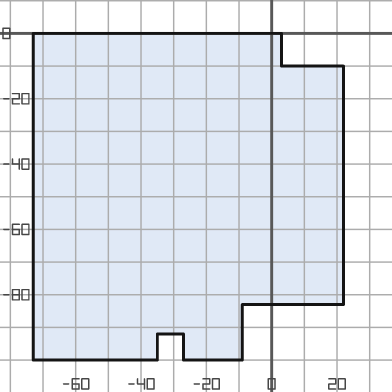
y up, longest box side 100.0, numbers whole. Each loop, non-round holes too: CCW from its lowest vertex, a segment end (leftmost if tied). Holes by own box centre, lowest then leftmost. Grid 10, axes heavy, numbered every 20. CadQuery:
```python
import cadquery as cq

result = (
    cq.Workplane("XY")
    .moveTo(-73.0, -100.0)
    .lineTo(-35.0, -100.0)
    .lineTo(-35.0, -92.0)
    .lineTo(-27.0, -92.0)
    .lineTo(-27.0, -100.0)
    .lineTo(-9.0, -100.0)
    .lineTo(-9.0, -83.0)
    .lineTo(22.0, -83.0)
    .lineTo(22.0, -10.0)
    .lineTo(3.0, -10.0)
    .lineTo(3.0, 0.0)
    .lineTo(-73.0, 0.0)
    .close()
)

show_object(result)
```